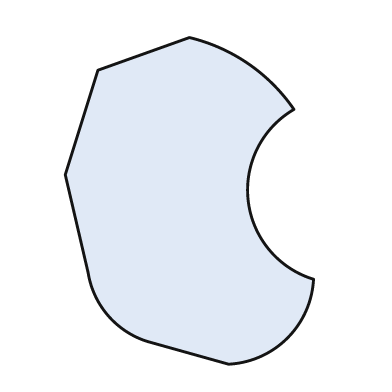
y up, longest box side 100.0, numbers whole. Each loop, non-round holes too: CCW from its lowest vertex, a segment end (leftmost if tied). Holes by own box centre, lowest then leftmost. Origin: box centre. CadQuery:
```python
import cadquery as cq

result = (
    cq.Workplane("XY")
    .moveTo(12.0, -50.0)
    .threePointArc((30.0, -42.0), (38.0, -24.0))
    .threePointArc((18.0, 0.0), (32.0, 28.0))
    .threePointArc((18.0, 42.0), (0.0, 50.0))
    .lineTo(-28.0, 40.0)
    .lineTo(-38.0, 8.0)
    .lineTo(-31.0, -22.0)
    .threePointArc((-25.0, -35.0), (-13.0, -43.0))
    .close()
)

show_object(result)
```